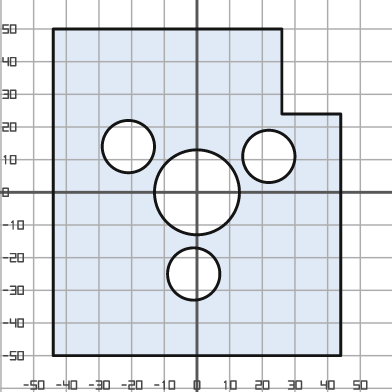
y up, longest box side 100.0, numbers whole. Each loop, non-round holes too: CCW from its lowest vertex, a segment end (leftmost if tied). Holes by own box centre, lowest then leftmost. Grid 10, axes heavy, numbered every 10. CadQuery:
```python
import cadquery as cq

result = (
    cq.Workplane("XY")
    .moveTo(-44.0, -50.0)
    .lineTo(44.0, -50.0)
    .lineTo(44.0, 24.0)
    .lineTo(26.0, 24.0)
    .lineTo(26.0, 50.0)
    .lineTo(-44.0, 50.0)
    .close()
    .moveTo(-1.0, -25.0)
    .circle(8.0)
    .moveTo(0.0, 0.0)
    .circle(13.0)
    .moveTo(22.0, 11.0)
    .circle(8.0)
    .moveTo(-21.0, 14.0)
    .circle(8.0)
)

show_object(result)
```